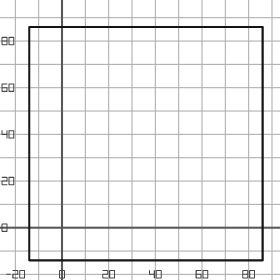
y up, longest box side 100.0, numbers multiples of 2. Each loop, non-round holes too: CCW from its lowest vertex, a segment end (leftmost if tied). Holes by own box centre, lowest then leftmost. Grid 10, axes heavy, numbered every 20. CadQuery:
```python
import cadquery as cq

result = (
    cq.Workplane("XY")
    .moveTo(-14.0, -14.0)
    .lineTo(86.0, -14.0)
    .lineTo(86.0, 86.0)
    .lineTo(-14.0, 86.0)
    .close()
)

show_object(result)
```